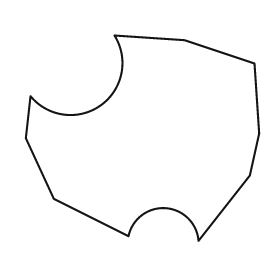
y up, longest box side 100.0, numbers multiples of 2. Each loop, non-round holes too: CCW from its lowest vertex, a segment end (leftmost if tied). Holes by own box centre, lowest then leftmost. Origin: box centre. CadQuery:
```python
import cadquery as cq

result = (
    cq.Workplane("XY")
    .moveTo(24.0, -44.0)
    .lineTo(46.0, -16.0)
    .lineTo(50.0, 2.0)
    .lineTo(48.0, 32.0)
    .lineTo(18.0, 42.0)
    .lineTo(-12.0, 44.0)
    .threePointArc((-18.0, 14.0), (-48.0, 18.0))
    .lineTo(-50.0, 0.0)
    .lineTo(-38.0, -26.0)
    .lineTo(-6.0, -42.0)
    .threePointArc((10.0, -30.0), (24.0, -44.0))
    .close()
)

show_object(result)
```